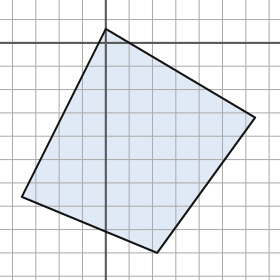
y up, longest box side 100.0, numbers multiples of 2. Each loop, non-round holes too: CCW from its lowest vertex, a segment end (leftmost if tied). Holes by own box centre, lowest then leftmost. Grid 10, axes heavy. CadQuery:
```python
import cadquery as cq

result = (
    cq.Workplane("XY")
    .moveTo(22.0, -90.0)
    .lineTo(64.0, -32.0)
    .lineTo(0.0, 6.0)
    .lineTo(-36.0, -66.0)
    .close()
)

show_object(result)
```